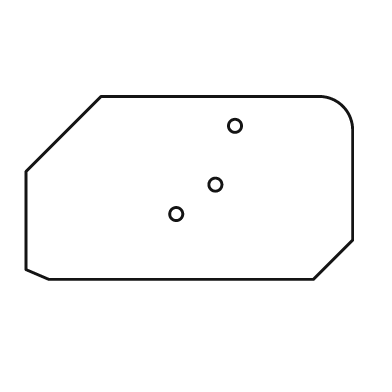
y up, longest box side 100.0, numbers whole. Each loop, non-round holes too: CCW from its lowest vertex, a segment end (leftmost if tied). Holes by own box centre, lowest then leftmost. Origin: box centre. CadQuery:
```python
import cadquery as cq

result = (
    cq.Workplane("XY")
    .moveTo(-43.0, -28.0)
    .lineTo(38.0, -28.0)
    .lineTo(50.0, -16.0)
    .lineTo(50.0, 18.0)
    .threePointArc((47.0, 25.0), (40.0, 28.0))
    .lineTo(-27.0, 28.0)
    .lineTo(-50.0, 5.0)
    .lineTo(-50.0, -25.0)
    .close()
    .moveTo(-4.0, -8.0)
    .circle(2.0)
    .moveTo(8.0, 1.0)
    .circle(2.0)
    .moveTo(14.0, 19.0)
    .circle(2.0)
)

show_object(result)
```